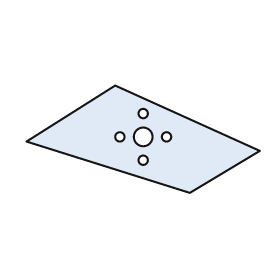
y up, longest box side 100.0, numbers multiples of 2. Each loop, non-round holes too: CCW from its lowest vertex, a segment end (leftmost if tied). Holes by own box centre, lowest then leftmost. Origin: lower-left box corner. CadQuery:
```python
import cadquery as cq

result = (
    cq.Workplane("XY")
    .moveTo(70.0, 0.0)
    .lineTo(100.0, 18.0)
    .lineTo(38.0, 46.0)
    .lineTo(0.0, 22.0)
    .close()
    .moveTo(50.0, 14.0)
    .circle(2.0)
    .moveTo(40.0, 24.0)
    .circle(2.0)
    .moveTo(50.0, 24.0)
    .circle(4.0)
    .moveTo(60.0, 24.0)
    .circle(2.0)
    .moveTo(50.0, 34.0)
    .circle(2.0)
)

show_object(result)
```